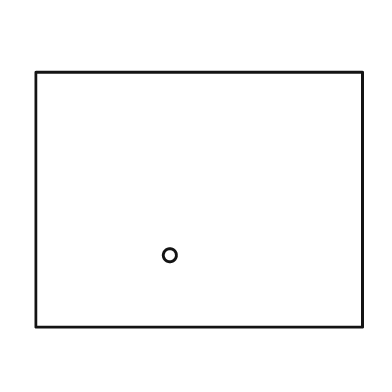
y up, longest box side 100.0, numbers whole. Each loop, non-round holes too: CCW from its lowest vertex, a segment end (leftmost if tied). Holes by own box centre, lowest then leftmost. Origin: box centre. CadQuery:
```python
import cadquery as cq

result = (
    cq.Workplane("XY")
    .moveTo(-50.0, -39.0)
    .lineTo(50.0, -39.0)
    .lineTo(50.0, 39.0)
    .lineTo(-50.0, 39.0)
    .close()
    .moveTo(-9.0, -17.0)
    .circle(2.0)
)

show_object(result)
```